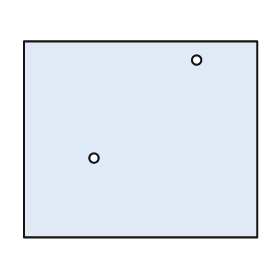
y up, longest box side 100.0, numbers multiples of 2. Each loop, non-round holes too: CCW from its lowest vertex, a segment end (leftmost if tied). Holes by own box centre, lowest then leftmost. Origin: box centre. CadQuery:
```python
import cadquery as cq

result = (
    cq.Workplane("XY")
    .moveTo(-50.0, -42.0)
    .lineTo(50.0, -42.0)
    .lineTo(50.0, 42.0)
    .lineTo(-50.0, 42.0)
    .close()
    .moveTo(-20.0, -8.0)
    .circle(2.0)
    .moveTo(24.0, 34.0)
    .circle(2.0)
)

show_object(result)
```